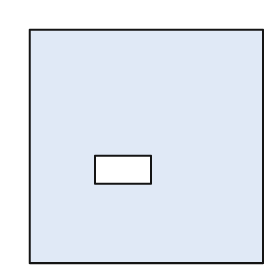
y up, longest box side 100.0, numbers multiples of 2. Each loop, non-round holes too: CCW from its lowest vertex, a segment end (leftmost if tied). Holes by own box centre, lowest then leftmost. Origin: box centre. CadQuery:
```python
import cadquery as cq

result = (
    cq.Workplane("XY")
    .moveTo(-50.0, -50.0)
    .lineTo(50.0, -50.0)
    .lineTo(50.0, 50.0)
    .lineTo(-50.0, 50.0)
    .close()
    .moveTo(-22.0, -16.0)
    .lineTo(2.0, -16.0)
    .lineTo(2.0, -4.0)
    .lineTo(-22.0, -4.0)
    .close()
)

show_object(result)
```